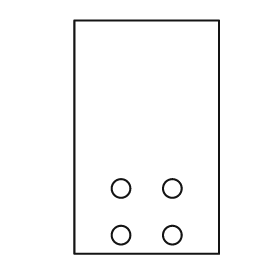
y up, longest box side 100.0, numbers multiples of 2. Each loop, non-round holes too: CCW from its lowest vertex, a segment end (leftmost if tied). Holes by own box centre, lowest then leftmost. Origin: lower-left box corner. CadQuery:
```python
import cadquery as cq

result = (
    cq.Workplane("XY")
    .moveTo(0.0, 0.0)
    .lineTo(62.0, 0.0)
    .lineTo(62.0, 100.0)
    .lineTo(0.0, 100.0)
    .close()
    .moveTo(20.0, 8.0)
    .circle(4.0)
    .moveTo(42.0, 8.0)
    .circle(4.0)
    .moveTo(20.0, 28.0)
    .circle(4.0)
    .moveTo(42.0, 28.0)
    .circle(4.0)
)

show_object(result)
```